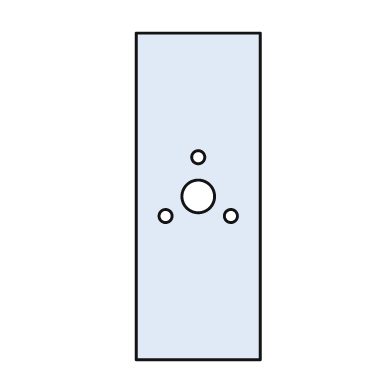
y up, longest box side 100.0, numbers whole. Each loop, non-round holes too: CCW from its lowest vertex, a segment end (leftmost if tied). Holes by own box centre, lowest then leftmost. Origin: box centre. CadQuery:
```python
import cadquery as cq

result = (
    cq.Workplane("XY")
    .moveTo(-19.0, -50.0)
    .lineTo(19.0, -50.0)
    .lineTo(19.0, 50.0)
    .lineTo(-19.0, 50.0)
    .close()
    .moveTo(-10.0, -6.0)
    .circle(2.0)
    .moveTo(10.0, -6.0)
    .circle(2.0)
    .moveTo(0.0, 0.0)
    .circle(5.0)
    .moveTo(0.0, 12.0)
    .circle(2.0)
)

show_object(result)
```